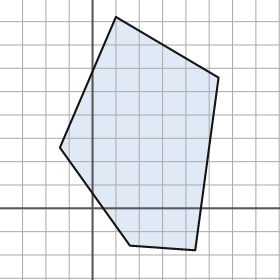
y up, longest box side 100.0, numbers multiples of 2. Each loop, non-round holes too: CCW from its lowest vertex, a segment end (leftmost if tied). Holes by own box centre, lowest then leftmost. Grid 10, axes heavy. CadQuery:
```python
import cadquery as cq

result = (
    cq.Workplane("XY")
    .moveTo(44.0, -18.0)
    .lineTo(54.0, 56.0)
    .lineTo(10.0, 82.0)
    .lineTo(-14.0, 26.0)
    .lineTo(16.0, -16.0)
    .close()
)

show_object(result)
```